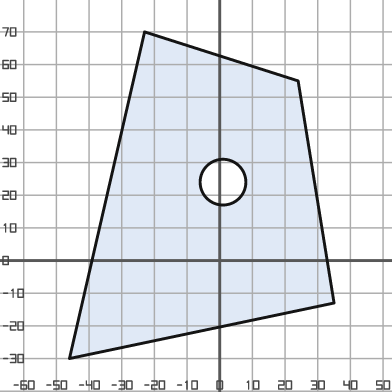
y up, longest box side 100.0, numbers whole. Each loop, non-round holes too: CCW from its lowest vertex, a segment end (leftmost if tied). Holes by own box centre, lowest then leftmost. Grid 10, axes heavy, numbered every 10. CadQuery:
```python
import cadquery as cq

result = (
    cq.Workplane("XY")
    .moveTo(-46.0, -30.0)
    .lineTo(35.0, -13.0)
    .lineTo(24.0, 55.0)
    .lineTo(-23.0, 70.0)
    .close()
    .moveTo(1.0, 24.0)
    .circle(7.0)
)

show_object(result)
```